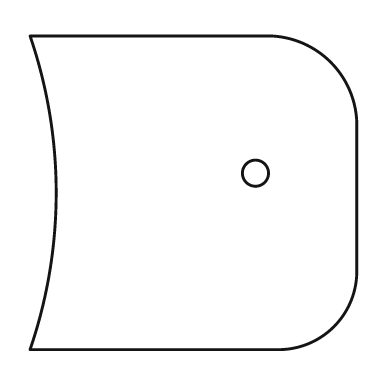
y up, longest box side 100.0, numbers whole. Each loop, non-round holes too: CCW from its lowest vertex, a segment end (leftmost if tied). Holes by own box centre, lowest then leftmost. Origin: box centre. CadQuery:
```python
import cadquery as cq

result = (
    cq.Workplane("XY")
    .moveTo(-50.0, -48.0)
    .lineTo(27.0, -48.0)
    .threePointArc((43.0, -41.0), (50.0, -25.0))
    .lineTo(50.0, 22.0)
    .threePointArc((42.0, 40.0), (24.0, 48.0))
    .lineTo(-50.0, 48.0)
    .threePointArc((-42.0, 0.0), (-50.0, -48.0))
    .close()
    .moveTo(19.0, 6.0)
    .circle(4.0)
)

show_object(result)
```